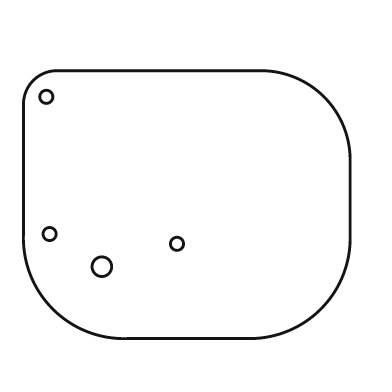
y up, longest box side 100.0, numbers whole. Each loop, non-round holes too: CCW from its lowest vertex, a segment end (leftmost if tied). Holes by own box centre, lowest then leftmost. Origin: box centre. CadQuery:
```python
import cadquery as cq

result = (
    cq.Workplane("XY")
    .moveTo(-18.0, -41.0)
    .lineTo(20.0, -41.0)
    .threePointArc((41.0, -32.0), (50.0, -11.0))
    .lineTo(50.0, 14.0)
    .threePointArc((42.0, 33.0), (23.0, 41.0))
    .lineTo(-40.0, 41.0)
    .threePointArc((-47.0, 38.0), (-50.0, 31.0))
    .lineTo(-50.0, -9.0)
    .threePointArc((-41.0, -32.0), (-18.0, -41.0))
    .close()
    .moveTo(-26.0, -19.0)
    .circle(3.0)
    .moveTo(-3.0, -12.0)
    .circle(2.0)
    .moveTo(-42.0, -9.0)
    .circle(2.0)
    .moveTo(-43.0, 33.0)
    .circle(2.0)
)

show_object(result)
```